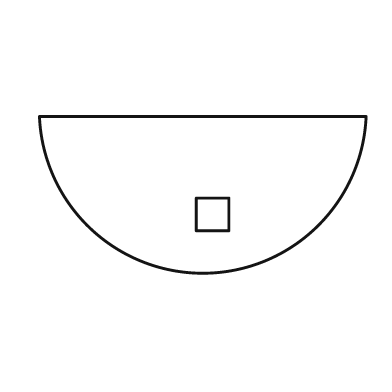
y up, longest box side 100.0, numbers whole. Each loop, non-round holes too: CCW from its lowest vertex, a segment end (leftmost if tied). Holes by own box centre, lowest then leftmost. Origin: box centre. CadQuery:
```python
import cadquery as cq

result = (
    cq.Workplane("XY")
    .moveTo(-50.0, 24.0)
    .threePointArc((0.0, -24.0), (50.0, 24.0))
    .close()
    .moveTo(-2.0, -11.0)
    .lineTo(8.0, -11.0)
    .lineTo(8.0, -1.0)
    .lineTo(-2.0, -1.0)
    .close()
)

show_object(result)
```